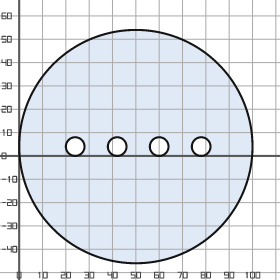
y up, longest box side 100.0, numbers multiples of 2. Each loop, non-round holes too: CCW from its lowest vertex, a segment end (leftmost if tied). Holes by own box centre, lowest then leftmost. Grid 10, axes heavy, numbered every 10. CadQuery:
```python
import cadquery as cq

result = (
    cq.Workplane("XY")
    .moveTo(50.0, 4.0)
    .circle(50.0)
    .moveTo(24.0, 4.0)
    .circle(4.0)
    .moveTo(42.0, 4.0)
    .circle(4.0)
    .moveTo(60.0, 4.0)
    .circle(4.0)
    .moveTo(78.0, 4.0)
    .circle(4.0)
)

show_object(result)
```